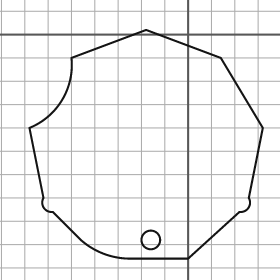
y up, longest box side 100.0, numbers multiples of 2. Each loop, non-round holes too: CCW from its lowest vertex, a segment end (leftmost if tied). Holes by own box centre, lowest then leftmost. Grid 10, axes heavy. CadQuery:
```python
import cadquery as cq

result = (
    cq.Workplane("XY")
    .moveTo(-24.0, -96.0)
    .lineTo(0.0, -96.0)
    .lineTo(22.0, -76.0)
    .threePointArc((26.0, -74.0), (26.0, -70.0))
    .lineTo(32.0, -40.0)
    .lineTo(14.0, -10.0)
    .lineTo(-18.0, 2.0)
    .lineTo(-50.0, -10.0)
    .threePointArc((-54.0, -28.0), (-68.0, -40.0))
    .lineTo(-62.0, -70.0)
    .threePointArc((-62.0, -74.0), (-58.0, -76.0))
    .lineTo(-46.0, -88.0)
    .threePointArc((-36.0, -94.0), (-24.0, -96.0))
    .close()
    .moveTo(-16.0, -88.0)
    .circle(4.0)
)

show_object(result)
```